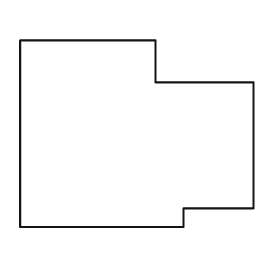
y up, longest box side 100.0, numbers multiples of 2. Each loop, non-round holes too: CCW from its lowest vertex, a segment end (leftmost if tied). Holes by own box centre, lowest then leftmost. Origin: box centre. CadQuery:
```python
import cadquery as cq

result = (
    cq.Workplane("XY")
    .moveTo(-50.0, -40.0)
    .lineTo(20.0, -40.0)
    .lineTo(20.0, -32.0)
    .lineTo(50.0, -32.0)
    .lineTo(50.0, 22.0)
    .lineTo(8.0, 22.0)
    .lineTo(8.0, 40.0)
    .lineTo(-50.0, 40.0)
    .close()
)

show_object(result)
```